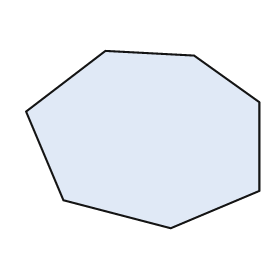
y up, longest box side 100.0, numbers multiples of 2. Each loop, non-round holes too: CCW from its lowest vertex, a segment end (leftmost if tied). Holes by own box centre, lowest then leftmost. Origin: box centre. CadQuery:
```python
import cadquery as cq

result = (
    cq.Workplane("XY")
    .moveTo(12.0, -38.0)
    .lineTo(50.0, -22.0)
    .lineTo(50.0, 16.0)
    .lineTo(22.0, 36.0)
    .lineTo(-16.0, 38.0)
    .lineTo(-50.0, 12.0)
    .lineTo(-34.0, -26.0)
    .close()
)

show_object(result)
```